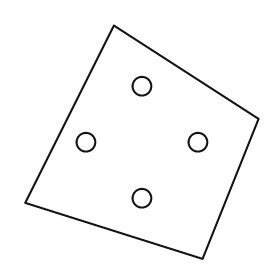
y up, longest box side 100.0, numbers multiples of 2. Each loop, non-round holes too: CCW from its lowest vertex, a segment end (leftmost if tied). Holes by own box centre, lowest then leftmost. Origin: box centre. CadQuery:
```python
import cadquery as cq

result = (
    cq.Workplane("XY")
    .moveTo(26.0, -50.0)
    .lineTo(50.0, 10.0)
    .lineTo(-12.0, 50.0)
    .lineTo(-50.0, -26.0)
    .close()
    .moveTo(0.0, -24.0)
    .circle(4.0)
    .moveTo(-24.0, 0.0)
    .circle(4.0)
    .moveTo(24.0, 0.0)
    .circle(4.0)
    .moveTo(0.0, 24.0)
    .circle(4.0)
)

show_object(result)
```